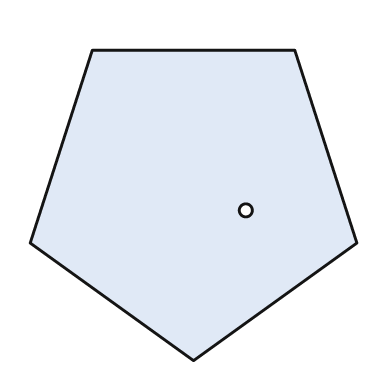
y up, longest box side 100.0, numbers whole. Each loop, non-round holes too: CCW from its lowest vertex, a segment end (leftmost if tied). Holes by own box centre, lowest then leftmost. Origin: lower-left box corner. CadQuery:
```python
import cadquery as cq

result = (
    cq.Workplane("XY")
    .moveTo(50.0, 0.0)
    .lineTo(100.0, 36.0)
    .lineTo(81.0, 95.0)
    .lineTo(19.0, 95.0)
    .lineTo(0.0, 36.0)
    .close()
    .moveTo(66.0, 46.0)
    .circle(2.0)
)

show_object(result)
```